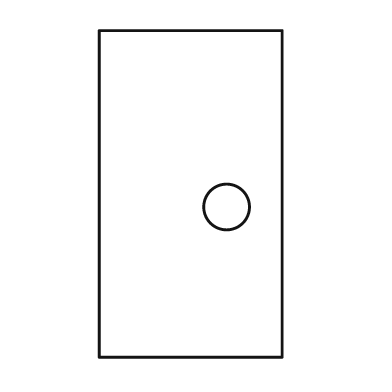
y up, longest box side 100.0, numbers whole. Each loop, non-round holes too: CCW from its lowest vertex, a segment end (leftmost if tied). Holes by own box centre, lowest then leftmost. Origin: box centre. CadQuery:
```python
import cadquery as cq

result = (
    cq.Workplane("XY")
    .moveTo(-28.0, -50.0)
    .lineTo(28.0, -50.0)
    .lineTo(28.0, 50.0)
    .lineTo(-28.0, 50.0)
    .close()
    .moveTo(11.0, -4.0)
    .circle(7.0)
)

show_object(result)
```